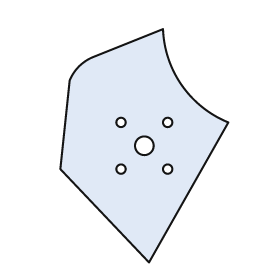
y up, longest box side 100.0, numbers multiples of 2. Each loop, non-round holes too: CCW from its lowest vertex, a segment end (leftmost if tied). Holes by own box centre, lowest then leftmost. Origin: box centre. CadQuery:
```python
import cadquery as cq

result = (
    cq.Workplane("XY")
    .moveTo(2.0, -50.0)
    .lineTo(36.0, 10.0)
    .threePointArc((16.0, 26.0), (8.0, 50.0))
    .lineTo(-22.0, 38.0)
    .threePointArc((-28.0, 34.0), (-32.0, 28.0))
    .lineTo(-36.0, -10.0)
    .close()
    .moveTo(-10.0, -10.0)
    .circle(2.0)
    .moveTo(10.0, -10.0)
    .circle(2.0)
    .moveTo(0.0, 0.0)
    .circle(4.0)
    .moveTo(-10.0, 10.0)
    .circle(2.0)
    .moveTo(10.0, 10.0)
    .circle(2.0)
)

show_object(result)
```